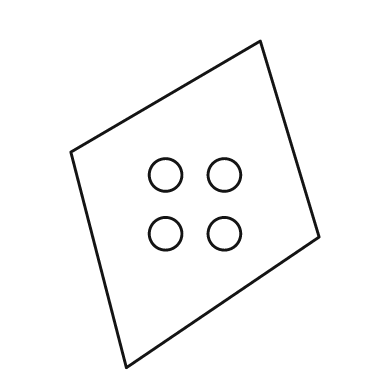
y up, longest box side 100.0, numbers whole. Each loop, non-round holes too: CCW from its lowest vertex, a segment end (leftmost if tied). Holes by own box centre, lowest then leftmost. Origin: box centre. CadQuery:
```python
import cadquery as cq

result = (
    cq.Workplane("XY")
    .moveTo(-21.0, -50.0)
    .lineTo(38.0, -10.0)
    .lineTo(20.0, 50.0)
    .lineTo(-38.0, 16.0)
    .close()
    .moveTo(-9.0, -9.0)
    .circle(5.0)
    .moveTo(9.0, -9.0)
    .circle(5.0)
    .moveTo(-9.0, 9.0)
    .circle(5.0)
    .moveTo(9.0, 9.0)
    .circle(5.0)
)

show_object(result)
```